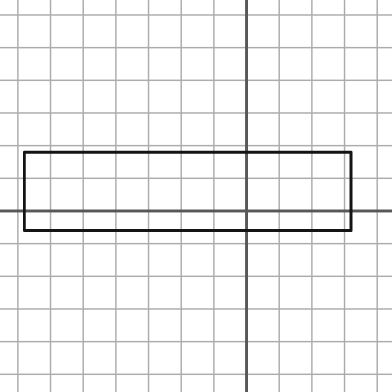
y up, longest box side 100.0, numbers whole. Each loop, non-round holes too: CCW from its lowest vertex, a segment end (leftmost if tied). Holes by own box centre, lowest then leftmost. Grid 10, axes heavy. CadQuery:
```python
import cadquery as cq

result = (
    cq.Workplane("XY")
    .moveTo(-68.0, -6.0)
    .lineTo(32.0, -6.0)
    .lineTo(32.0, 18.0)
    .lineTo(-68.0, 18.0)
    .close()
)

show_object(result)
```